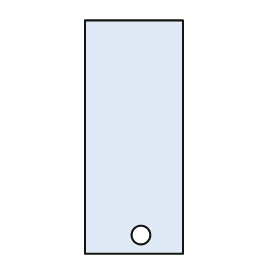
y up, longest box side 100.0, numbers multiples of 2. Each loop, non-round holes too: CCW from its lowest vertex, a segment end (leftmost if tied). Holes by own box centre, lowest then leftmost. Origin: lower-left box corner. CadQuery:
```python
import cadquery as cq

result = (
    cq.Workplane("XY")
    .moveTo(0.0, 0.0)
    .lineTo(42.0, 0.0)
    .lineTo(42.0, 100.0)
    .lineTo(0.0, 100.0)
    .close()
    .moveTo(24.0, 8.0)
    .circle(4.0)
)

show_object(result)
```